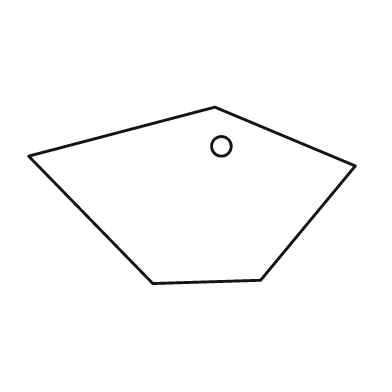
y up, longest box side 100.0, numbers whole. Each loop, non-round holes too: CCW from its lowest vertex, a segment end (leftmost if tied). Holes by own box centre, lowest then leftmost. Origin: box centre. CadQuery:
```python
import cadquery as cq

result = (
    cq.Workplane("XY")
    .moveTo(-12.0, -27.0)
    .lineTo(21.0, -26.0)
    .lineTo(50.0, 9.0)
    .lineTo(7.0, 27.0)
    .lineTo(-50.0, 12.0)
    .close()
    .moveTo(9.0, 15.0)
    .circle(3.0)
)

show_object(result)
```